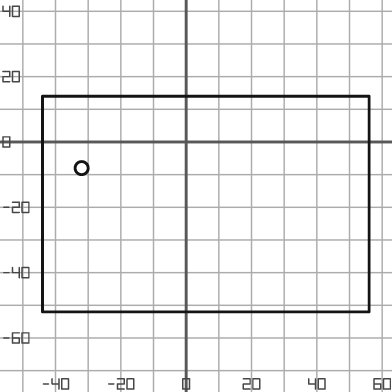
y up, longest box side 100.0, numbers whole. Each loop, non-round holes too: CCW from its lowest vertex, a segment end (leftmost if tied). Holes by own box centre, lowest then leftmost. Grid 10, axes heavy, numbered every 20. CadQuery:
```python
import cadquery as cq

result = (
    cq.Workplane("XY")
    .moveTo(-44.0, -52.0)
    .lineTo(56.0, -52.0)
    .lineTo(56.0, 14.0)
    .lineTo(-44.0, 14.0)
    .close()
    .moveTo(-32.0, -8.0)
    .circle(2.0)
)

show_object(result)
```